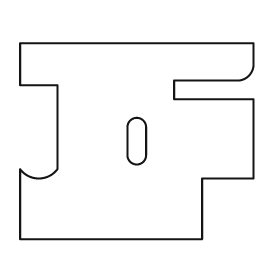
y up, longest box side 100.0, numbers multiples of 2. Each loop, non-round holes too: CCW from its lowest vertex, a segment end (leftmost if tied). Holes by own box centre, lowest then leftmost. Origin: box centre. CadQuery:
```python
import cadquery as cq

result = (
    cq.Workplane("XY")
    .moveTo(-50.0, -42.0)
    .lineTo(28.0, -42.0)
    .lineTo(28.0, -16.0)
    .lineTo(50.0, -16.0)
    .lineTo(50.0, 18.0)
    .lineTo(16.0, 18.0)
    .lineTo(16.0, 26.0)
    .lineTo(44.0, 26.0)
    .threePointArc((48.0, 28.0), (50.0, 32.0))
    .lineTo(50.0, 42.0)
    .lineTo(-50.0, 42.0)
    .lineTo(-50.0, 24.0)
    .lineTo(-34.0, 24.0)
    .lineTo(-34.0, -12.0)
    .threePointArc((-42.0, -16.0), (-50.0, -12.0))
    .close()
    .moveTo(-4.0, -6.0)
    .threePointArc((0.0, -10.0), (4.0, -6.0))
    .lineTo(4.0, 6.0)
    .threePointArc((0.0, 10.0), (-4.0, 6.0))
    .close()
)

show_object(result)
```